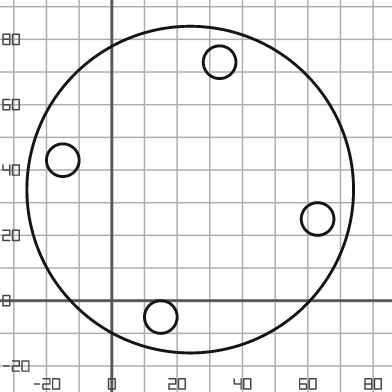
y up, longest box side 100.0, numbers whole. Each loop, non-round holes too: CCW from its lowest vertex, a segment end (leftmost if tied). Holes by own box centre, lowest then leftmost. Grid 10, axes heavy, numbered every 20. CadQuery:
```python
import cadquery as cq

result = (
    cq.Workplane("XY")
    .moveTo(24.0, 34.0)
    .circle(50.0)
    .moveTo(15.0, -5.0)
    .circle(5.0)
    .moveTo(63.0, 25.0)
    .circle(5.0)
    .moveTo(-15.0, 43.0)
    .circle(5.0)
    .moveTo(33.0, 73.0)
    .circle(5.0)
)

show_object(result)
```